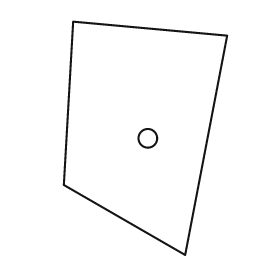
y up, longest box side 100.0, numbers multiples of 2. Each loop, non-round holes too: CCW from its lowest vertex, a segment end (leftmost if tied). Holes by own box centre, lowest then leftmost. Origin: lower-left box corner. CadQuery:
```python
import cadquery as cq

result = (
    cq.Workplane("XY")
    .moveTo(52.0, 0.0)
    .lineTo(70.0, 94.0)
    .lineTo(4.0, 100.0)
    .lineTo(0.0, 30.0)
    .close()
    .moveTo(36.0, 50.0)
    .circle(4.0)
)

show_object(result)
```